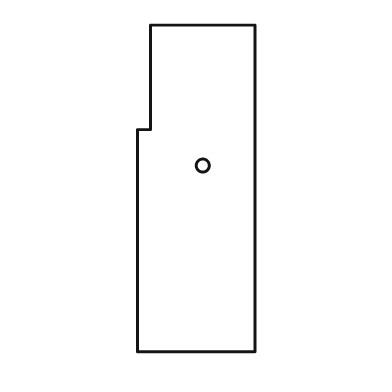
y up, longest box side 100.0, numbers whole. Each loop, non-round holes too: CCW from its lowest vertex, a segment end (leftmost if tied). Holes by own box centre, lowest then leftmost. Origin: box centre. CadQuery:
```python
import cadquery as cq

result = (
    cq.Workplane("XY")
    .moveTo(-18.0, -50.0)
    .lineTo(18.0, -50.0)
    .lineTo(18.0, 50.0)
    .lineTo(-14.0, 50.0)
    .lineTo(-14.0, 18.0)
    .lineTo(-18.0, 18.0)
    .close()
    .moveTo(2.0, 7.0)
    .circle(2.0)
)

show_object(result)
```